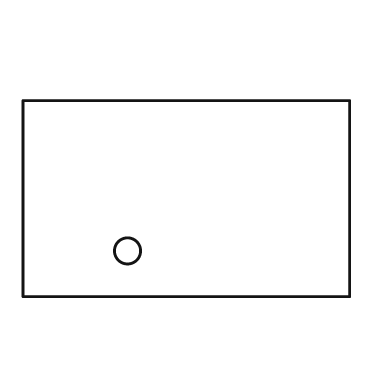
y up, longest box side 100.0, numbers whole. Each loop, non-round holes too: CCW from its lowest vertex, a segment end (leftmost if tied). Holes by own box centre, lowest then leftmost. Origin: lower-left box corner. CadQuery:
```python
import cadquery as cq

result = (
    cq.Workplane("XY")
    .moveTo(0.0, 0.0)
    .lineTo(100.0, 0.0)
    .lineTo(100.0, 60.0)
    .lineTo(0.0, 60.0)
    .close()
    .moveTo(32.0, 14.0)
    .circle(4.0)
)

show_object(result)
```